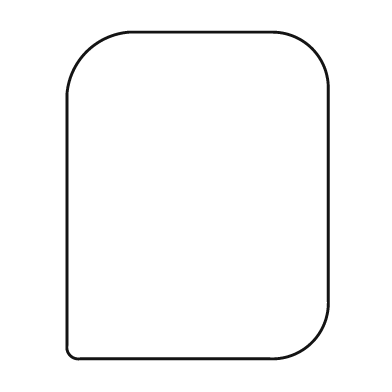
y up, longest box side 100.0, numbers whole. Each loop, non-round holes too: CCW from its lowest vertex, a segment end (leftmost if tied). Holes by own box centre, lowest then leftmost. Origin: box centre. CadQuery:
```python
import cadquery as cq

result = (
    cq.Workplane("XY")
    .moveTo(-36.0, -50.0)
    .lineTo(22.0, -50.0)
    .threePointArc((35.0, -45.0), (40.0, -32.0))
    .lineTo(40.0, 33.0)
    .threePointArc((35.0, 45.0), (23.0, 50.0))
    .lineTo(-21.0, 50.0)
    .threePointArc((-34.0, 44.0), (-40.0, 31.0))
    .lineTo(-40.0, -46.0)
    .threePointArc((-39.0, -49.0), (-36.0, -50.0))
    .close()
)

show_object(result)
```